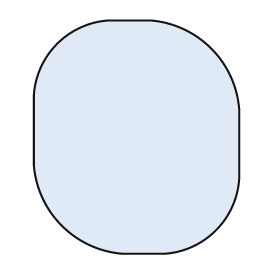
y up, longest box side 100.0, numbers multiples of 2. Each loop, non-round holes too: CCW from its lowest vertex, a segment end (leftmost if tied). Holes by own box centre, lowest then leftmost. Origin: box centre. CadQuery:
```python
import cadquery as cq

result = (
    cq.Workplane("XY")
    .moveTo(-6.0, -50.0)
    .lineTo(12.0, -50.0)
    .threePointArc((34.0, -40.0), (44.0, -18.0))
    .lineTo(44.0, 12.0)
    .threePointArc((32.0, 38.0), (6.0, 50.0))
    .lineTo(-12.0, 50.0)
    .threePointArc((-34.0, 40.0), (-44.0, 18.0))
    .lineTo(-44.0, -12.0)
    .threePointArc((-32.0, -38.0), (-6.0, -50.0))
    .close()
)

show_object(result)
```